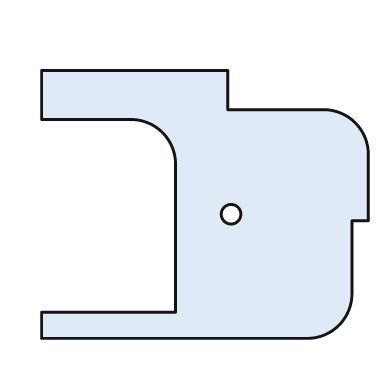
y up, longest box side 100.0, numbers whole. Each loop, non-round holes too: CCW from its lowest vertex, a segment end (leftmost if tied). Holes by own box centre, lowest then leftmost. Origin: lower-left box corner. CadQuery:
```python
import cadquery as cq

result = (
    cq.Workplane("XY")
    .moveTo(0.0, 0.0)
    .lineTo(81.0, 0.0)
    .threePointArc((91.0, 4.0), (95.0, 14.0))
    .lineTo(95.0, 36.0)
    .lineTo(100.0, 36.0)
    .lineTo(100.0, 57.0)
    .threePointArc((96.0, 66.0), (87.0, 70.0))
    .lineTo(57.0, 70.0)
    .lineTo(57.0, 82.0)
    .lineTo(0.0, 82.0)
    .lineTo(0.0, 67.0)
    .lineTo(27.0, 67.0)
    .threePointArc((37.0, 63.0), (41.0, 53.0))
    .lineTo(41.0, 8.0)
    .lineTo(0.0, 8.0)
    .close()
    .moveTo(58.0, 38.0)
    .circle(3.0)
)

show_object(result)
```